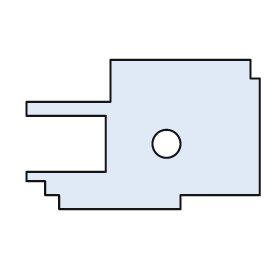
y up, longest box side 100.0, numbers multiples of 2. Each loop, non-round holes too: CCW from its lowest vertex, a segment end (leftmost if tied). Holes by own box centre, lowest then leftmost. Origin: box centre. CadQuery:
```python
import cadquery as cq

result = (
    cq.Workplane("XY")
    .moveTo(-36.0, -32.0)
    .lineTo(16.0, -32.0)
    .lineTo(16.0, -26.0)
    .lineTo(50.0, -26.0)
    .lineTo(50.0, 24.0)
    .lineTo(46.0, 24.0)
    .lineTo(46.0, 32.0)
    .lineTo(-14.0, 32.0)
    .lineTo(-14.0, 14.0)
    .lineTo(-50.0, 14.0)
    .lineTo(-50.0, 8.0)
    .lineTo(-16.0, 8.0)
    .lineTo(-16.0, -16.0)
    .lineTo(-50.0, -16.0)
    .lineTo(-50.0, -20.0)
    .lineTo(-42.0, -20.0)
    .lineTo(-42.0, -26.0)
    .lineTo(-36.0, -26.0)
    .close()
    .moveTo(10.0, -4.0)
    .circle(6.0)
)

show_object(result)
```